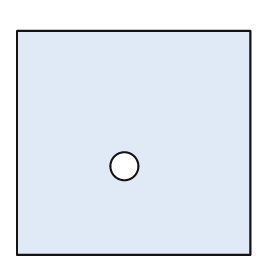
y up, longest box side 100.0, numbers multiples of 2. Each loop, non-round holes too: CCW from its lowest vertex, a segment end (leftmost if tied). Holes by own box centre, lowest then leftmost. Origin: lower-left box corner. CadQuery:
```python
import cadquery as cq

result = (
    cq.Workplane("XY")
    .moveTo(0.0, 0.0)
    .lineTo(100.0, 0.0)
    .lineTo(100.0, 96.0)
    .lineTo(0.0, 96.0)
    .close()
    .moveTo(46.0, 38.0)
    .circle(6.0)
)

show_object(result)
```